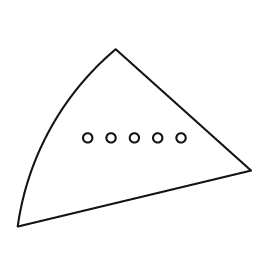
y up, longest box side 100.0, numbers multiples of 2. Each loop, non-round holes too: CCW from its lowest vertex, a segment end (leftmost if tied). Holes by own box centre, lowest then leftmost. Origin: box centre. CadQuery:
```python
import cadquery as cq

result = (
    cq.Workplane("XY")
    .moveTo(-50.0, -38.0)
    .lineTo(50.0, -14.0)
    .lineTo(-8.0, 38.0)
    .threePointArc((-36.0, 4.0), (-50.0, -38.0))
    .close()
    .moveTo(-20.0, 0.0)
    .circle(2.0)
    .moveTo(-10.0, 0.0)
    .circle(2.0)
    .moveTo(0.0, 0.0)
    .circle(2.0)
    .moveTo(10.0, 0.0)
    .circle(2.0)
    .moveTo(20.0, 0.0)
    .circle(2.0)
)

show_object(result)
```